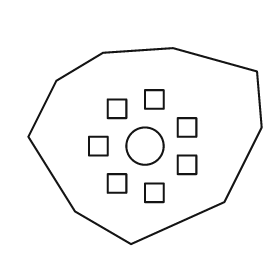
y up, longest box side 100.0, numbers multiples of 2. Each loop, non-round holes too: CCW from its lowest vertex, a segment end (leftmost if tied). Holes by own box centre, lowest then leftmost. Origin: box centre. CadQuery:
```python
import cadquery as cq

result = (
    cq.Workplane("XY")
    .moveTo(-6.0, -42.0)
    .lineTo(34.0, -24.0)
    .lineTo(50.0, 8.0)
    .lineTo(48.0, 32.0)
    .lineTo(12.0, 42.0)
    .lineTo(-18.0, 40.0)
    .lineTo(-38.0, 28.0)
    .lineTo(-50.0, 4.0)
    .lineTo(-30.0, -28.0)
    .close()
    .moveTo(0.0, -24.0)
    .lineTo(8.0, -24.0)
    .lineTo(8.0, -16.0)
    .lineTo(0.0, -16.0)
    .close()
    .moveTo(-16.0, -20.0)
    .lineTo(-8.0, -20.0)
    .lineTo(-8.0, -12.0)
    .lineTo(-16.0, -12.0)
    .close()
    .moveTo(14.0, -12.0)
    .lineTo(22.0, -12.0)
    .lineTo(22.0, -4.0)
    .lineTo(14.0, -4.0)
    .close()
    .moveTo(-24.0, -4.0)
    .lineTo(-16.0, -4.0)
    .lineTo(-16.0, 4.0)
    .lineTo(-24.0, 4.0)
    .close()
    .moveTo(0.0, 0.0)
    .circle(8.0)
    .moveTo(14.0, 4.0)
    .lineTo(22.0, 4.0)
    .lineTo(22.0, 12.0)
    .lineTo(14.0, 12.0)
    .close()
    .moveTo(-16.0, 12.0)
    .lineTo(-8.0, 12.0)
    .lineTo(-8.0, 20.0)
    .lineTo(-16.0, 20.0)
    .close()
    .moveTo(0.0, 16.0)
    .lineTo(8.0, 16.0)
    .lineTo(8.0, 24.0)
    .lineTo(0.0, 24.0)
    .close()
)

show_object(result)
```